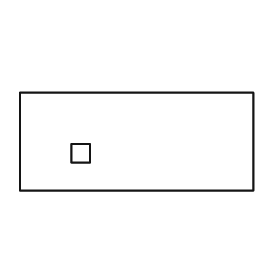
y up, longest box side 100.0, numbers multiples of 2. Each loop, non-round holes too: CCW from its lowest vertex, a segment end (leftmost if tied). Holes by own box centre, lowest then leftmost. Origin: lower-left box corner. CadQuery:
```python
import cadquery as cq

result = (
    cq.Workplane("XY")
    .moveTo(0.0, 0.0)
    .lineTo(100.0, 0.0)
    .lineTo(100.0, 42.0)
    .lineTo(0.0, 42.0)
    .close()
    .moveTo(22.0, 12.0)
    .lineTo(30.0, 12.0)
    .lineTo(30.0, 20.0)
    .lineTo(22.0, 20.0)
    .close()
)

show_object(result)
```